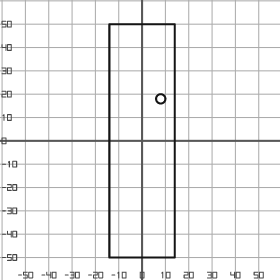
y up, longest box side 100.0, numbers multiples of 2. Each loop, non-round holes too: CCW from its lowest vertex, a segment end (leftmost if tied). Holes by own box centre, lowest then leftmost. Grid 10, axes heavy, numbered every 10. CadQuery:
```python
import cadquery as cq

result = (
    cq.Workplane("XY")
    .moveTo(-14.0, -50.0)
    .lineTo(14.0, -50.0)
    .lineTo(14.0, 50.0)
    .lineTo(-14.0, 50.0)
    .close()
    .moveTo(8.0, 18.0)
    .circle(2.0)
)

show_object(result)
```